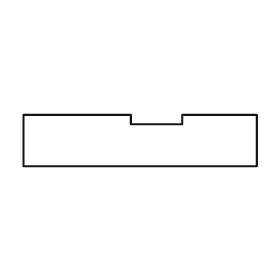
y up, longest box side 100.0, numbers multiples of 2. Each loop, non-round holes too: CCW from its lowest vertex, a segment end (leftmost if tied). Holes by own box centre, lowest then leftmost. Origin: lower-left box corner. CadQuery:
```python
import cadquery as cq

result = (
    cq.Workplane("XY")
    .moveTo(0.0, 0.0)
    .lineTo(100.0, 0.0)
    .lineTo(100.0, 22.0)
    .lineTo(68.0, 22.0)
    .lineTo(68.0, 18.0)
    .lineTo(46.0, 18.0)
    .lineTo(46.0, 22.0)
    .lineTo(0.0, 22.0)
    .close()
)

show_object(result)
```